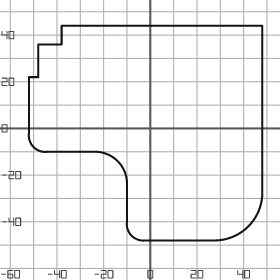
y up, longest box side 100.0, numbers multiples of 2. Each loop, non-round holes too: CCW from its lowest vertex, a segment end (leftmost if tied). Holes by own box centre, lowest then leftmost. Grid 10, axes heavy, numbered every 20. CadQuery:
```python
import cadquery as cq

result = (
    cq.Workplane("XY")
    .moveTo(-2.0, -48.0)
    .lineTo(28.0, -48.0)
    .threePointArc((42.0, -42.0), (48.0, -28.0))
    .lineTo(48.0, 44.0)
    .lineTo(-38.0, 44.0)
    .lineTo(-38.0, 36.0)
    .lineTo(-48.0, 36.0)
    .lineTo(-48.0, 22.0)
    .lineTo(-52.0, 22.0)
    .lineTo(-52.0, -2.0)
    .threePointArc((-50.0, -8.0), (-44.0, -10.0))
    .lineTo(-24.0, -10.0)
    .threePointArc((-14.0, -14.0), (-10.0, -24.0))
    .lineTo(-10.0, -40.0)
    .threePointArc((-8.0, -46.0), (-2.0, -48.0))
    .close()
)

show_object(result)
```